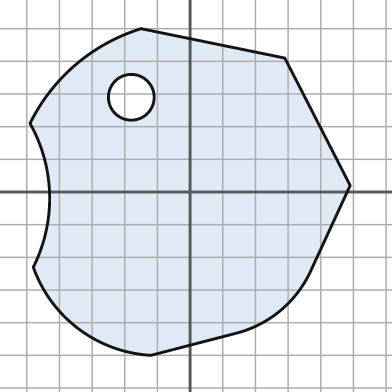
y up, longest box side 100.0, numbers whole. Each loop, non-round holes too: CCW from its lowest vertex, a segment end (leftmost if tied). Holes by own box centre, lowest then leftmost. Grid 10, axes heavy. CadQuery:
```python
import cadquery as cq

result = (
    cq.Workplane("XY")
    .moveTo(-12.0, -50.0)
    .lineTo(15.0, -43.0)
    .threePointArc((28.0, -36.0), (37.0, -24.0))
    .lineTo(49.0, 2.0)
    .lineTo(29.0, 41.0)
    .lineTo(-15.0, 50.0)
    .threePointArc((-35.0, 39.0), (-49.0, 21.0))
    .threePointArc((-43.0, -1.0), (-48.0, -23.0))
    .threePointArc((-34.0, -42.0), (-12.0, -50.0))
    .close()
    .moveTo(-18.0, 29.0)
    .circle(7.0)
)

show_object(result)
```